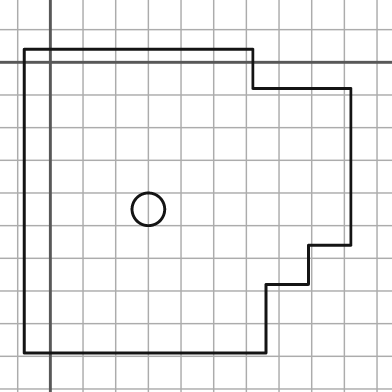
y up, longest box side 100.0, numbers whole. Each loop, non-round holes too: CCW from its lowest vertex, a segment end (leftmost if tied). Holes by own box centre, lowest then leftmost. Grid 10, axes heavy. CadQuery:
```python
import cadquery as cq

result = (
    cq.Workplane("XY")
    .moveTo(-8.0, -89.0)
    .lineTo(66.0, -89.0)
    .lineTo(66.0, -68.0)
    .lineTo(79.0, -68.0)
    .lineTo(79.0, -56.0)
    .lineTo(92.0, -56.0)
    .lineTo(92.0, -8.0)
    .lineTo(62.0, -8.0)
    .lineTo(62.0, 4.0)
    .lineTo(-8.0, 4.0)
    .close()
    .moveTo(30.0, -45.0)
    .circle(5.0)
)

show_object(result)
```